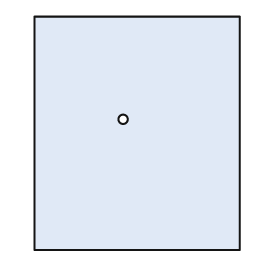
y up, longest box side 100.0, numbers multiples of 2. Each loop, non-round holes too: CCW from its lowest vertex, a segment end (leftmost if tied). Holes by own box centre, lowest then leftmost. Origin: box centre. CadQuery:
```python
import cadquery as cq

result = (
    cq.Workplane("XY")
    .moveTo(-44.0, -50.0)
    .lineTo(44.0, -50.0)
    .lineTo(44.0, 50.0)
    .lineTo(-44.0, 50.0)
    .close()
    .moveTo(-6.0, 6.0)
    .circle(2.0)
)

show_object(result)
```